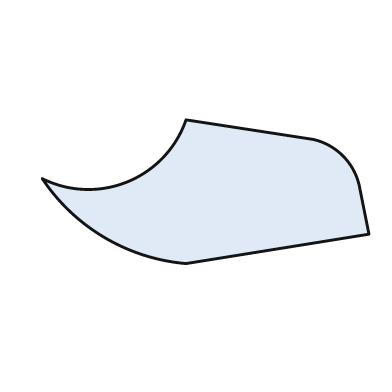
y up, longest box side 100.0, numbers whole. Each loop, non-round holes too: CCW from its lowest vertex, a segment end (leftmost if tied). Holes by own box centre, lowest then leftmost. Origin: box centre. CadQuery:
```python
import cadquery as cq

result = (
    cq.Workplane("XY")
    .moveTo(-6.0, -22.0)
    .lineTo(50.0, -13.0)
    .lineTo(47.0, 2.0)
    .threePointArc((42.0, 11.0), (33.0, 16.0))
    .lineTo(-6.0, 22.0)
    .threePointArc((-24.0, 3.0), (-50.0, 4.0))
    .threePointArc((-31.0, -14.0), (-6.0, -22.0))
    .close()
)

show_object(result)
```